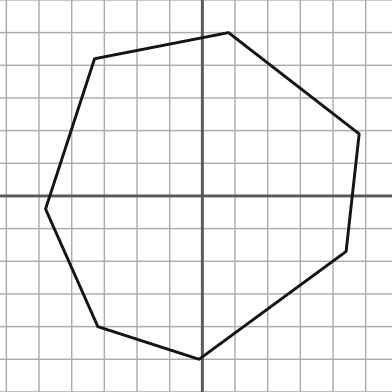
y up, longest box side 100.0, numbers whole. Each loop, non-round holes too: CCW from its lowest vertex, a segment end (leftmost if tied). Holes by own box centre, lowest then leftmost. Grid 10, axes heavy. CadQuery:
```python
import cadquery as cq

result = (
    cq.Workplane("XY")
    .moveTo(-1.0, -50.0)
    .lineTo(44.0, -17.0)
    .lineTo(48.0, 19.0)
    .lineTo(8.0, 50.0)
    .lineTo(-33.0, 42.0)
    .lineTo(-48.0, -4.0)
    .lineTo(-32.0, -40.0)
    .close()
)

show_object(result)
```